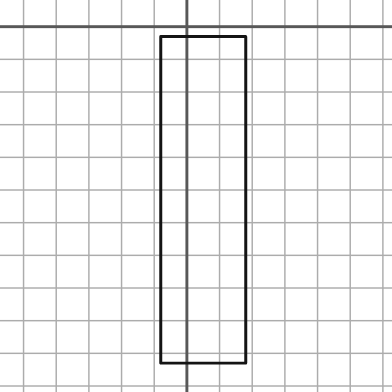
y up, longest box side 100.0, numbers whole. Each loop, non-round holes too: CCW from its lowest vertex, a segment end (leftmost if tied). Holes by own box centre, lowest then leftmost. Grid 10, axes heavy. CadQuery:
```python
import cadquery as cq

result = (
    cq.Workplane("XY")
    .moveTo(-8.0, -103.0)
    .lineTo(18.0, -103.0)
    .lineTo(18.0, -3.0)
    .lineTo(-8.0, -3.0)
    .close()
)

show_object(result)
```